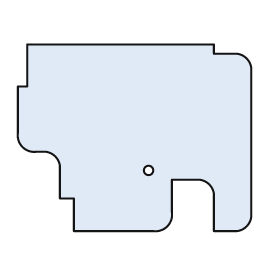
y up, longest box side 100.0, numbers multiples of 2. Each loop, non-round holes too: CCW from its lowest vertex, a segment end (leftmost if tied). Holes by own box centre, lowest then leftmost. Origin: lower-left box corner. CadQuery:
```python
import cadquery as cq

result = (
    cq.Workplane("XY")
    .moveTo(24.0, 0.0)
    .lineTo(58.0, 0.0)
    .threePointArc((64.0, 2.0), (66.0, 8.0))
    .lineTo(66.0, 22.0)
    .lineTo(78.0, 22.0)
    .threePointArc((82.0, 20.0), (84.0, 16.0))
    .lineTo(84.0, 0.0)
    .lineTo(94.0, 0.0)
    .threePointArc((98.0, 2.0), (100.0, 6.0))
    .lineTo(100.0, 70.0)
    .threePointArc((98.0, 74.0), (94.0, 76.0))
    .lineTo(84.0, 76.0)
    .lineTo(84.0, 80.0)
    .lineTo(4.0, 80.0)
    .lineTo(4.0, 62.0)
    .lineTo(0.0, 62.0)
    .lineTo(0.0, 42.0)
    .threePointArc((2.0, 36.0), (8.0, 34.0))
    .lineTo(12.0, 34.0)
    .threePointArc((16.0, 32.0), (18.0, 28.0))
    .lineTo(18.0, 14.0)
    .lineTo(24.0, 14.0)
    .close()
    .moveTo(56.0, 26.0)
    .circle(2.0)
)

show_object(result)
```